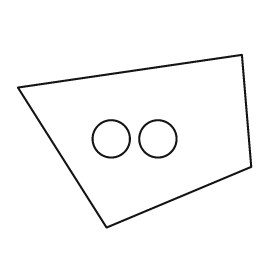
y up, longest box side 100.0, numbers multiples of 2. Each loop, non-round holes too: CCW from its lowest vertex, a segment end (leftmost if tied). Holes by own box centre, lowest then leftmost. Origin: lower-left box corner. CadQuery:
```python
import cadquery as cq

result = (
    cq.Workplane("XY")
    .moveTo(38.0, 0.0)
    .lineTo(100.0, 26.0)
    .lineTo(96.0, 74.0)
    .lineTo(0.0, 60.0)
    .close()
    .moveTo(40.0, 38.0)
    .circle(8.0)
    .moveTo(60.0, 38.0)
    .circle(8.0)
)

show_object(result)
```